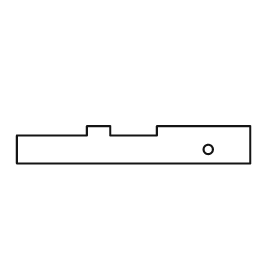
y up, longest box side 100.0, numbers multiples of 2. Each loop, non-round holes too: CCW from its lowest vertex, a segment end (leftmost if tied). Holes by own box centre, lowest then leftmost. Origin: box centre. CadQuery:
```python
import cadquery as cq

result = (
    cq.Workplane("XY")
    .moveTo(-50.0, -8.0)
    .lineTo(50.0, -8.0)
    .lineTo(50.0, 8.0)
    .lineTo(10.0, 8.0)
    .lineTo(10.0, 4.0)
    .lineTo(-10.0, 4.0)
    .lineTo(-10.0, 8.0)
    .lineTo(-20.0, 8.0)
    .lineTo(-20.0, 4.0)
    .lineTo(-50.0, 4.0)
    .close()
    .moveTo(32.0, -2.0)
    .circle(2.0)
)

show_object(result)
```